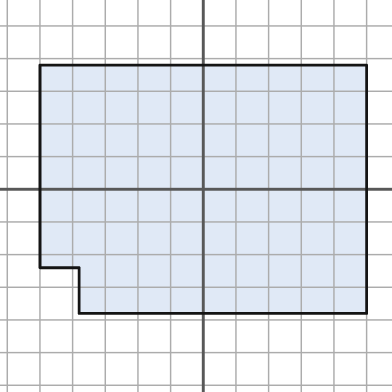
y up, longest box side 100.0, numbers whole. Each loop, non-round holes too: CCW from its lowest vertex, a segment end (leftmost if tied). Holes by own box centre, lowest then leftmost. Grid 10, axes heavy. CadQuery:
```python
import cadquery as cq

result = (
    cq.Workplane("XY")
    .moveTo(-38.0, -38.0)
    .lineTo(50.0, -38.0)
    .lineTo(50.0, 38.0)
    .lineTo(-50.0, 38.0)
    .lineTo(-50.0, -24.0)
    .lineTo(-38.0, -24.0)
    .close()
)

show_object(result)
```